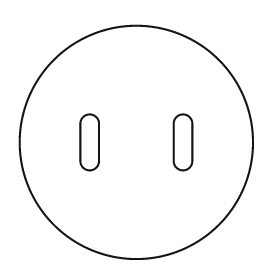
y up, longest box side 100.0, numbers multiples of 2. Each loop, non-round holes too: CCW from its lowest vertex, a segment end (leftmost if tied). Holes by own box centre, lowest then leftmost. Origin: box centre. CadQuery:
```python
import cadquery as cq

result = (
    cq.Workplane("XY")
    .moveTo(0.0, 0.0)
    .circle(50.0)
    .moveTo(-24.0, -8.0)
    .threePointArc((-20.0, -12.0), (-16.0, -8.0))
    .lineTo(-16.0, 8.0)
    .threePointArc((-20.0, 12.0), (-24.0, 8.0))
    .close()
    .moveTo(16.0, -8.0)
    .threePointArc((20.0, -12.0), (24.0, -8.0))
    .lineTo(24.0, 8.0)
    .threePointArc((20.0, 12.0), (16.0, 8.0))
    .close()
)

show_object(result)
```